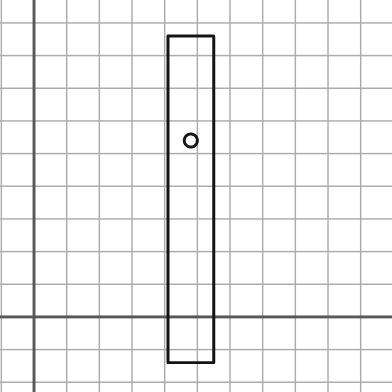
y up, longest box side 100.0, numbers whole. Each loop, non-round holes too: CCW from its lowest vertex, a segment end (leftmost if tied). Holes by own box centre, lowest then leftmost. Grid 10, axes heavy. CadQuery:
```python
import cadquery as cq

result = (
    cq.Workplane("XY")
    .moveTo(41.0, -14.0)
    .lineTo(55.0, -14.0)
    .lineTo(55.0, 86.0)
    .lineTo(41.0, 86.0)
    .close()
    .moveTo(48.0, 54.0)
    .circle(2.0)
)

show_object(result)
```